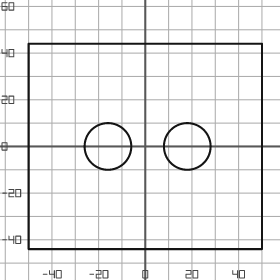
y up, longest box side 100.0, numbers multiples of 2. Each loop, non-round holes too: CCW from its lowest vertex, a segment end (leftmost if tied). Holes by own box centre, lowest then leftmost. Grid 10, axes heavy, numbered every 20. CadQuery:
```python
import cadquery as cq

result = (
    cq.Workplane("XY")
    .moveTo(-50.0, -44.0)
    .lineTo(50.0, -44.0)
    .lineTo(50.0, 44.0)
    .lineTo(-50.0, 44.0)
    .close()
    .moveTo(-16.0, 0.0)
    .circle(10.0)
    .moveTo(18.0, 0.0)
    .circle(10.0)
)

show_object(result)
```